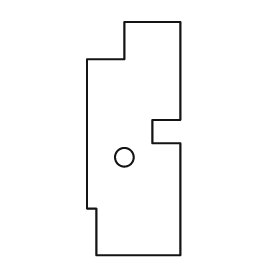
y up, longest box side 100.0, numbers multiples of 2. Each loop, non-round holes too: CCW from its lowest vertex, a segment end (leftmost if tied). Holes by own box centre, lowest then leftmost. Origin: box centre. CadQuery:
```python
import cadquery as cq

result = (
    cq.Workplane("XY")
    .moveTo(-16.0, -50.0)
    .lineTo(20.0, -50.0)
    .lineTo(20.0, -2.0)
    .lineTo(8.0, -2.0)
    .lineTo(8.0, 8.0)
    .lineTo(20.0, 8.0)
    .lineTo(20.0, 50.0)
    .lineTo(-4.0, 50.0)
    .lineTo(-4.0, 34.0)
    .lineTo(-20.0, 34.0)
    .lineTo(-20.0, -30.0)
    .lineTo(-16.0, -30.0)
    .close()
    .moveTo(-4.0, -8.0)
    .circle(4.0)
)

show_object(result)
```